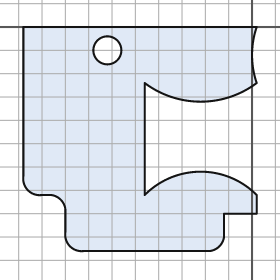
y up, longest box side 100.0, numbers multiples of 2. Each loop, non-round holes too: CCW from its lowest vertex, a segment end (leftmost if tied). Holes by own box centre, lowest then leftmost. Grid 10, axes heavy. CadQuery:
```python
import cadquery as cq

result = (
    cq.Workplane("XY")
    .moveTo(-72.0, -96.0)
    .lineTo(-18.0, -96.0)
    .threePointArc((-14.0, -94.0), (-12.0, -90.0))
    .lineTo(-12.0, -80.0)
    .lineTo(2.0, -80.0)
    .lineTo(2.0, -72.0)
    .threePointArc((-22.0, -62.0), (-46.0, -72.0))
    .lineTo(-46.0, -24.0)
    .threePointArc((-22.0, -32.0), (2.0, -24.0))
    .threePointArc((0.0, -12.0), (2.0, 0.0))
    .lineTo(-98.0, 0.0)
    .lineTo(-98.0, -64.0)
    .threePointArc((-96.0, -70.0), (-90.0, -72.0))
    .lineTo(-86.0, -72.0)
    .threePointArc((-82.0, -74.0), (-80.0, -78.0))
    .lineTo(-80.0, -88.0)
    .threePointArc((-78.0, -94.0), (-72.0, -96.0))
    .close()
    .moveTo(-62.0, -10.0)
    .circle(6.0)
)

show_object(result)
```